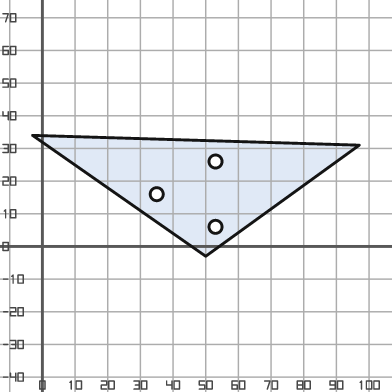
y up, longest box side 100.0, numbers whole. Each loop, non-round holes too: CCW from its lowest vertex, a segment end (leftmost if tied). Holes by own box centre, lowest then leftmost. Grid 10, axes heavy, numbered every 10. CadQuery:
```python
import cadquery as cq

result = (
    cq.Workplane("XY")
    .moveTo(50.0, -3.0)
    .lineTo(97.0, 31.0)
    .lineTo(-3.0, 34.0)
    .close()
    .moveTo(53.0, 6.0)
    .circle(2.0)
    .moveTo(35.0, 16.0)
    .circle(2.0)
    .moveTo(53.0, 26.0)
    .circle(2.0)
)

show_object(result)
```